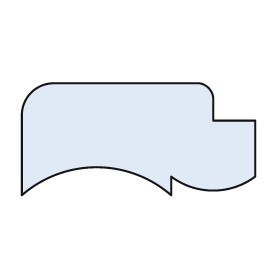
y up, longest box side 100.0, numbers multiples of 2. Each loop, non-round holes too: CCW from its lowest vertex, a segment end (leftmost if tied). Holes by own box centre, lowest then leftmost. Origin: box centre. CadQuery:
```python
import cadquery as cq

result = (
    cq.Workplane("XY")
    .moveTo(-50.0, -24.0)
    .threePointArc((-18.0, -12.0), (14.0, -24.0))
    .lineTo(14.0, -16.0)
    .threePointArc((32.0, -22.0), (50.0, -16.0))
    .lineTo(50.0, 8.0)
    .lineTo(32.0, 8.0)
    .lineTo(32.0, 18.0)
    .threePointArc((30.0, 22.0), (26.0, 24.0))
    .lineTo(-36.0, 24.0)
    .threePointArc((-46.0, 20.0), (-50.0, 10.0))
    .close()
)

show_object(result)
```